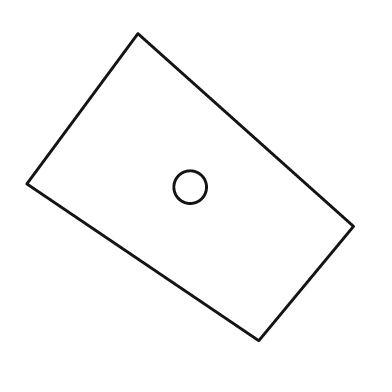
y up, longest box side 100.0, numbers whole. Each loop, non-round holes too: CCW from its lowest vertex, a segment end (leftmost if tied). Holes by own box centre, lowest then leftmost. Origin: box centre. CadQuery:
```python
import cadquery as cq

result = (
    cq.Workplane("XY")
    .moveTo(21.0, -47.0)
    .lineTo(50.0, -12.0)
    .lineTo(-16.0, 47.0)
    .lineTo(-50.0, 1.0)
    .close()
    .moveTo(0.0, 0.0)
    .circle(5.0)
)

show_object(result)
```